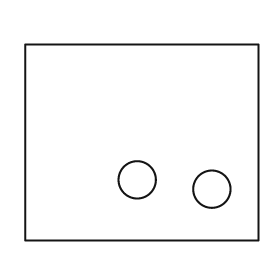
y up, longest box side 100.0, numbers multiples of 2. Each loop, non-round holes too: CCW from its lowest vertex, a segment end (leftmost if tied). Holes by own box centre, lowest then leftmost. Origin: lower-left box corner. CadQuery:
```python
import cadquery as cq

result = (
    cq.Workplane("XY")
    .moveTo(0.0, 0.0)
    .lineTo(100.0, 0.0)
    .lineTo(100.0, 84.0)
    .lineTo(0.0, 84.0)
    .close()
    .moveTo(80.0, 22.0)
    .circle(8.0)
    .moveTo(48.0, 26.0)
    .circle(8.0)
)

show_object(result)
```